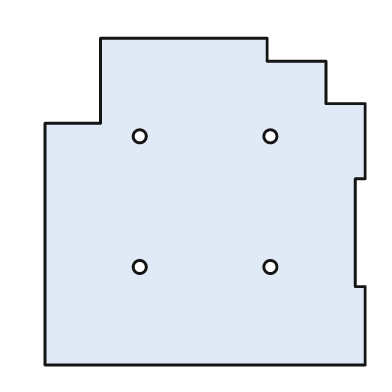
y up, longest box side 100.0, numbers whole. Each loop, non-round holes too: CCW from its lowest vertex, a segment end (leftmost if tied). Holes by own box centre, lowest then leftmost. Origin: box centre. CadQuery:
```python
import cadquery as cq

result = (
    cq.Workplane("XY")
    .moveTo(-49.0, -50.0)
    .lineTo(49.0, -50.0)
    .lineTo(49.0, -26.0)
    .lineTo(46.0, -26.0)
    .lineTo(46.0, 7.0)
    .lineTo(49.0, 7.0)
    .lineTo(49.0, 30.0)
    .lineTo(37.0, 30.0)
    .lineTo(37.0, 43.0)
    .lineTo(19.0, 43.0)
    .lineTo(19.0, 50.0)
    .lineTo(-32.0, 50.0)
    .lineTo(-32.0, 24.0)
    .lineTo(-49.0, 24.0)
    .close()
    .moveTo(-20.0, -20.0)
    .circle(2.0)
    .moveTo(20.0, -20.0)
    .circle(2.0)
    .moveTo(-20.0, 20.0)
    .circle(2.0)
    .moveTo(20.0, 20.0)
    .circle(2.0)
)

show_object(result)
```